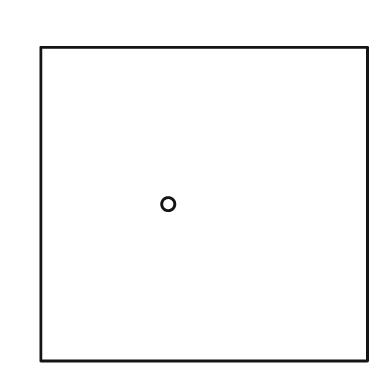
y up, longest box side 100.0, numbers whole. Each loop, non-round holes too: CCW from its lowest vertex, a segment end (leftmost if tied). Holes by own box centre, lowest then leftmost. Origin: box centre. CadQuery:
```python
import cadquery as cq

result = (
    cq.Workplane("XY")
    .moveTo(-50.0, -48.0)
    .lineTo(50.0, -48.0)
    .lineTo(50.0, 48.0)
    .lineTo(-50.0, 48.0)
    .close()
    .moveTo(-11.0, 0.0)
    .circle(2.0)
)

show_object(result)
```